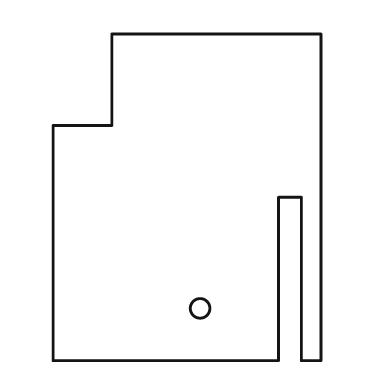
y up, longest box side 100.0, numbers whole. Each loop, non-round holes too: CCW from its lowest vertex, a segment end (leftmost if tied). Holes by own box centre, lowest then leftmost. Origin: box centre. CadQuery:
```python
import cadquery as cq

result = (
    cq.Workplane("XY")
    .moveTo(-41.0, -50.0)
    .lineTo(28.0, -50.0)
    .lineTo(28.0, 0.0)
    .lineTo(35.0, 0.0)
    .lineTo(35.0, -50.0)
    .lineTo(41.0, -50.0)
    .lineTo(41.0, 50.0)
    .lineTo(-23.0, 50.0)
    .lineTo(-23.0, 22.0)
    .lineTo(-41.0, 22.0)
    .close()
    .moveTo(4.0, -34.0)
    .circle(3.0)
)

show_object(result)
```